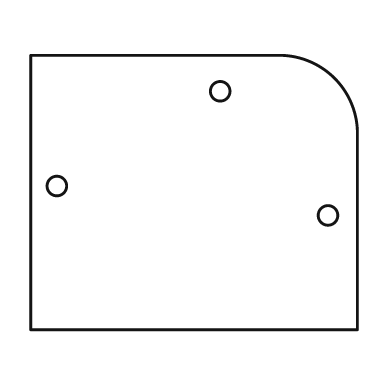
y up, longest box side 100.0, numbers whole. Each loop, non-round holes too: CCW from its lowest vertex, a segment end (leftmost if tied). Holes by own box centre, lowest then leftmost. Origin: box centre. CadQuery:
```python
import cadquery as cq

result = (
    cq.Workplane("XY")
    .moveTo(-50.0, -42.0)
    .lineTo(50.0, -42.0)
    .lineTo(50.0, 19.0)
    .threePointArc((43.0, 35.0), (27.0, 42.0))
    .lineTo(-50.0, 42.0)
    .close()
    .moveTo(41.0, -7.0)
    .circle(3.0)
    .moveTo(-42.0, 2.0)
    .circle(3.0)
    .moveTo(8.0, 31.0)
    .circle(3.0)
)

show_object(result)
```